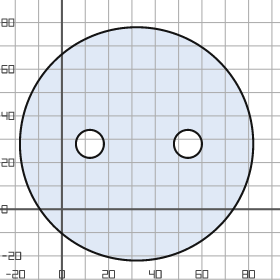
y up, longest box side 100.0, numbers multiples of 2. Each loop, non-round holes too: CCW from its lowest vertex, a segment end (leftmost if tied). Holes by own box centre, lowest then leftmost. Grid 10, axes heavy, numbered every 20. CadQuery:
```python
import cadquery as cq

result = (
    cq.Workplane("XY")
    .moveTo(32.0, 28.0)
    .circle(50.0)
    .moveTo(12.0, 28.0)
    .circle(6.0)
    .moveTo(54.0, 28.0)
    .circle(6.0)
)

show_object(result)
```